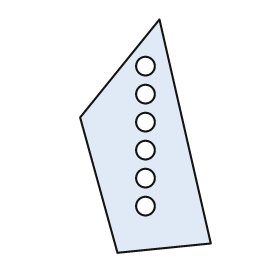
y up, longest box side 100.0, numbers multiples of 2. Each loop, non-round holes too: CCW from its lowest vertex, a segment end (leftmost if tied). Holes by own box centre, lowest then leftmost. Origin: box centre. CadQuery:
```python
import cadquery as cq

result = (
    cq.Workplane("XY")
    .moveTo(-12.0, -50.0)
    .lineTo(28.0, -46.0)
    .lineTo(6.0, 50.0)
    .lineTo(-28.0, 8.0)
    .close()
    .moveTo(0.0, -30.0)
    .circle(4.0)
    .moveTo(0.0, -18.0)
    .circle(4.0)
    .moveTo(0.0, -6.0)
    .circle(4.0)
    .moveTo(0.0, 6.0)
    .circle(4.0)
    .moveTo(0.0, 18.0)
    .circle(4.0)
    .moveTo(0.0, 30.0)
    .circle(4.0)
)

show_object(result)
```